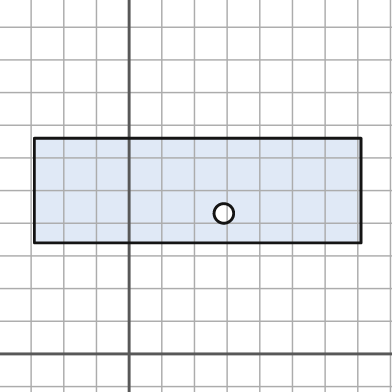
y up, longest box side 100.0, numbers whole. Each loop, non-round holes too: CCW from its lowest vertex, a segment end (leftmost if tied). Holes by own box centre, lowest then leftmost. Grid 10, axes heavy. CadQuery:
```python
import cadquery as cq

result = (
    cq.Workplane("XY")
    .moveTo(-29.0, 34.0)
    .lineTo(71.0, 34.0)
    .lineTo(71.0, 66.0)
    .lineTo(-29.0, 66.0)
    .close()
    .moveTo(29.0, 43.0)
    .circle(3.0)
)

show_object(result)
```